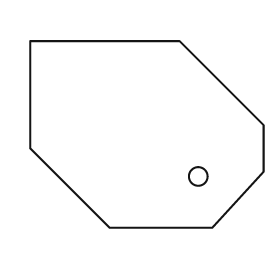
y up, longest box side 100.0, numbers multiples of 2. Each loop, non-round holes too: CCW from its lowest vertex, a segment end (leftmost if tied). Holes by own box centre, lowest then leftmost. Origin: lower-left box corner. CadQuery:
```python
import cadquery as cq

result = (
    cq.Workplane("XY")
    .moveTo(34.0, 0.0)
    .lineTo(78.0, 0.0)
    .lineTo(100.0, 24.0)
    .lineTo(100.0, 44.0)
    .lineTo(64.0, 80.0)
    .lineTo(0.0, 80.0)
    .lineTo(0.0, 34.0)
    .close()
    .moveTo(72.0, 22.0)
    .circle(4.0)
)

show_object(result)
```